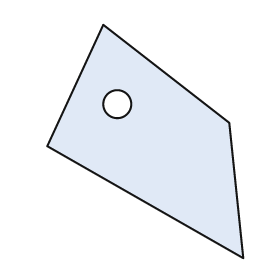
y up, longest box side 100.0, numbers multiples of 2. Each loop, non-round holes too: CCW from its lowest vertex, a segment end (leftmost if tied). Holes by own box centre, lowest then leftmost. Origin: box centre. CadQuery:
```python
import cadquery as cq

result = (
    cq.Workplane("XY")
    .moveTo(42.0, -50.0)
    .lineTo(36.0, 8.0)
    .lineTo(-18.0, 50.0)
    .lineTo(-42.0, -2.0)
    .close()
    .moveTo(-12.0, 16.0)
    .circle(6.0)
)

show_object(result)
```